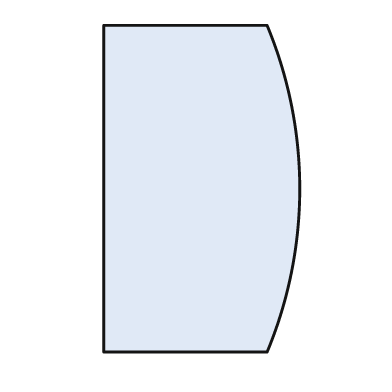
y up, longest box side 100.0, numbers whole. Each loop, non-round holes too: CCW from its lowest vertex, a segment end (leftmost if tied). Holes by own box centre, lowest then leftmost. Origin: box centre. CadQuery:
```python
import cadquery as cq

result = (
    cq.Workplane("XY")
    .moveTo(-30.0, -50.0)
    .lineTo(20.0, -50.0)
    .threePointArc((30.0, 0.0), (20.0, 50.0))
    .lineTo(-30.0, 50.0)
    .close()
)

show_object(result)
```